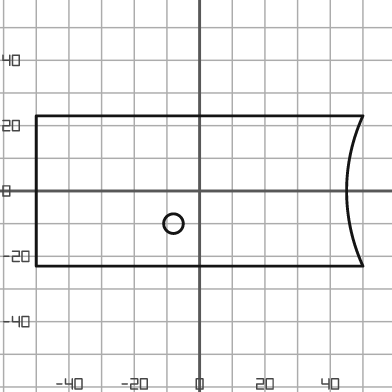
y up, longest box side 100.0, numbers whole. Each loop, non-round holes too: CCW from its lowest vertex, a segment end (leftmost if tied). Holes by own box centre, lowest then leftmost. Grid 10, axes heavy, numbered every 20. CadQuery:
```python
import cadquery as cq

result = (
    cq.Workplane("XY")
    .moveTo(-50.0, -23.0)
    .lineTo(50.0, -23.0)
    .threePointArc((45.0, 0.0), (50.0, 23.0))
    .lineTo(-50.0, 23.0)
    .close()
    .moveTo(-8.0, -10.0)
    .circle(3.0)
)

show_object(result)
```